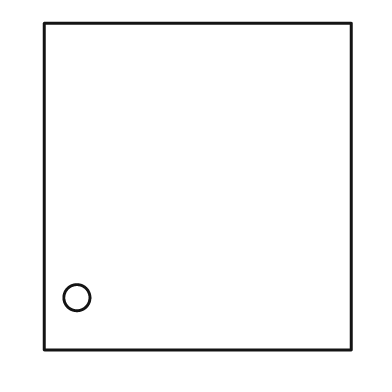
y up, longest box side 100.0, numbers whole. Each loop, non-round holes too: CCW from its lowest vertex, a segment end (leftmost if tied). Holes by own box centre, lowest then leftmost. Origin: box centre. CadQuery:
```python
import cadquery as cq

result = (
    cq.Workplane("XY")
    .moveTo(-47.0, -50.0)
    .lineTo(47.0, -50.0)
    .lineTo(47.0, 50.0)
    .lineTo(-47.0, 50.0)
    .close()
    .moveTo(-37.0, -34.0)
    .circle(4.0)
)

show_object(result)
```